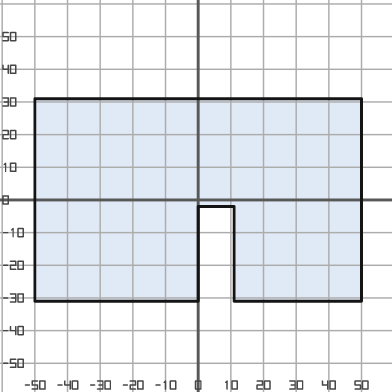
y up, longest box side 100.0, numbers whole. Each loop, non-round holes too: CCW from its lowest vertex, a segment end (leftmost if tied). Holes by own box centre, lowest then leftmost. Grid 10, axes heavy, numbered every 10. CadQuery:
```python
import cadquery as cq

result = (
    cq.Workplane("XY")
    .moveTo(-50.0, -31.0)
    .lineTo(0.0, -31.0)
    .lineTo(0.0, -2.0)
    .lineTo(11.0, -2.0)
    .lineTo(11.0, -31.0)
    .lineTo(50.0, -31.0)
    .lineTo(50.0, 31.0)
    .lineTo(-50.0, 31.0)
    .close()
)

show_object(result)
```